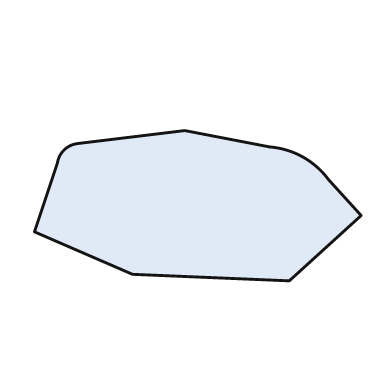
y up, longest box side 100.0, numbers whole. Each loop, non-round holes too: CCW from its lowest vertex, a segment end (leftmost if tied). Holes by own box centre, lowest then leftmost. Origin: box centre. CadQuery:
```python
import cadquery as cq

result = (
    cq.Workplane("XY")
    .moveTo(28.0, -23.0)
    .lineTo(50.0, -3.0)
    .lineTo(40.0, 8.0)
    .threePointArc((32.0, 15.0), (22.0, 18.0))
    .lineTo(-4.0, 23.0)
    .lineTo(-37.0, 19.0)
    .threePointArc((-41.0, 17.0), (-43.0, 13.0))
    .lineTo(-50.0, -8.0)
    .lineTo(-20.0, -21.0)
    .close()
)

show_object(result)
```